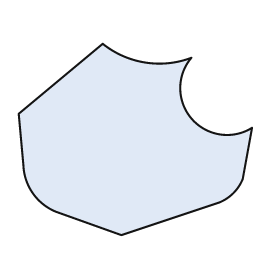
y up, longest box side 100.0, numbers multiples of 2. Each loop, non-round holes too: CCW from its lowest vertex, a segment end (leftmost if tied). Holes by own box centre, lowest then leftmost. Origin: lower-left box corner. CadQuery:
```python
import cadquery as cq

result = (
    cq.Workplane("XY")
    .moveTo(44.0, 0.0)
    .lineTo(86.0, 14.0)
    .threePointArc((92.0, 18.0), (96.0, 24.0))
    .lineTo(100.0, 46.0)
    .threePointArc((74.0, 50.0), (74.0, 76.0))
    .threePointArc((54.0, 74.0), (36.0, 82.0))
    .lineTo(0.0, 52.0)
    .lineTo(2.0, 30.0)
    .threePointArc((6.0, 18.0), (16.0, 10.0))
    .close()
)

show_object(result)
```